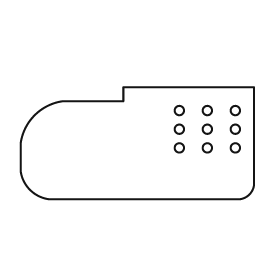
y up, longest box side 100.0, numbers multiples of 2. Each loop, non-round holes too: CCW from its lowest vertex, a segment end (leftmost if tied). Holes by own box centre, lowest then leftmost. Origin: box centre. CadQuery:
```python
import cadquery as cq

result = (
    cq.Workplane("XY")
    .moveTo(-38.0, -24.0)
    .lineTo(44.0, -24.0)
    .threePointArc((48.0, -22.0), (50.0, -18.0))
    .lineTo(50.0, 24.0)
    .lineTo(-6.0, 24.0)
    .lineTo(-6.0, 18.0)
    .lineTo(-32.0, 18.0)
    .threePointArc((-44.0, 12.0), (-50.0, 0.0))
    .lineTo(-50.0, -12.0)
    .threePointArc((-46.0, -20.0), (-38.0, -24.0))
    .close()
    .moveTo(18.0, -2.0)
    .circle(2.0)
    .moveTo(30.0, -2.0)
    .circle(2.0)
    .moveTo(42.0, -2.0)
    .circle(2.0)
    .moveTo(18.0, 6.0)
    .circle(2.0)
    .moveTo(30.0, 6.0)
    .circle(2.0)
    .moveTo(42.0, 6.0)
    .circle(2.0)
    .moveTo(18.0, 14.0)
    .circle(2.0)
    .moveTo(30.0, 14.0)
    .circle(2.0)
    .moveTo(42.0, 14.0)
    .circle(2.0)
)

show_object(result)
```